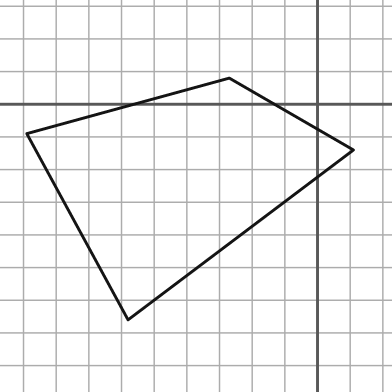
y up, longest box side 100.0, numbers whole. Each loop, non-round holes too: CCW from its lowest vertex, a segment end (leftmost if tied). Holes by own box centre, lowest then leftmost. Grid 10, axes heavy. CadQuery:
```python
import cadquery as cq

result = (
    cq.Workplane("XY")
    .moveTo(-58.0, -66.0)
    .lineTo(11.0, -14.0)
    .lineTo(-27.0, 8.0)
    .lineTo(-89.0, -9.0)
    .close()
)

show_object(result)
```